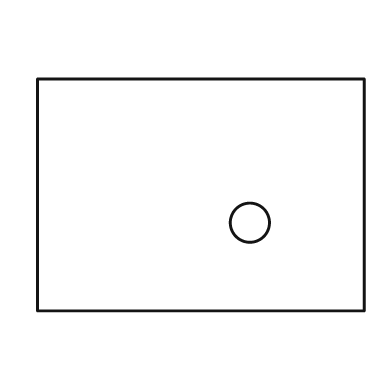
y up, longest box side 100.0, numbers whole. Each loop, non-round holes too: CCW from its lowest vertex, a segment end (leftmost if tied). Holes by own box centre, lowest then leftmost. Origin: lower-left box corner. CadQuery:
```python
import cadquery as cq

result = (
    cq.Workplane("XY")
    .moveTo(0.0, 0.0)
    .lineTo(100.0, 0.0)
    .lineTo(100.0, 71.0)
    .lineTo(0.0, 71.0)
    .close()
    .moveTo(65.0, 27.0)
    .circle(6.0)
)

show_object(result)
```